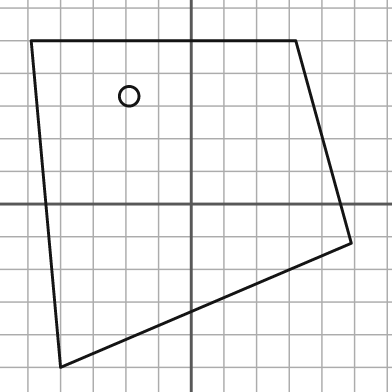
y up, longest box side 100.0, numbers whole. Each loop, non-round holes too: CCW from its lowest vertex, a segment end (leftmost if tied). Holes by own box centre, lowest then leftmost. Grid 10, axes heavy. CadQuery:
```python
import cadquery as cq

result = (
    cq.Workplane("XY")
    .moveTo(-40.0, -50.0)
    .lineTo(49.0, -12.0)
    .lineTo(32.0, 50.0)
    .lineTo(-49.0, 50.0)
    .close()
    .moveTo(-19.0, 33.0)
    .circle(3.0)
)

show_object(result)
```